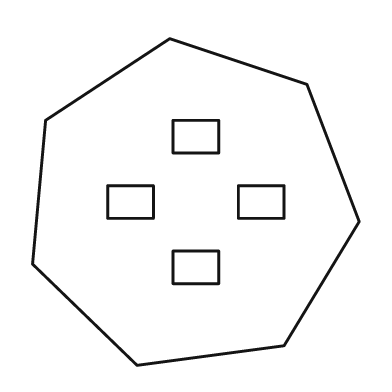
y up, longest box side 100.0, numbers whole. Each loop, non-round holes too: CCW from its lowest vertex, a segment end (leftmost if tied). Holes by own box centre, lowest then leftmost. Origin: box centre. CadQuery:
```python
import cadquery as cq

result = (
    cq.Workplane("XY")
    .moveTo(-18.0, -50.0)
    .lineTo(27.0, -44.0)
    .lineTo(50.0, -6.0)
    .lineTo(34.0, 36.0)
    .lineTo(-8.0, 50.0)
    .lineTo(-46.0, 25.0)
    .lineTo(-50.0, -19.0)
    .close()
    .moveTo(-7.0, -25.0)
    .lineTo(7.0, -25.0)
    .lineTo(7.0, -15.0)
    .lineTo(-7.0, -15.0)
    .close()
    .moveTo(-27.0, -5.0)
    .lineTo(-13.0, -5.0)
    .lineTo(-13.0, 5.0)
    .lineTo(-27.0, 5.0)
    .close()
    .moveTo(13.0, -5.0)
    .lineTo(27.0, -5.0)
    .lineTo(27.0, 5.0)
    .lineTo(13.0, 5.0)
    .close()
    .moveTo(-7.0, 15.0)
    .lineTo(7.0, 15.0)
    .lineTo(7.0, 25.0)
    .lineTo(-7.0, 25.0)
    .close()
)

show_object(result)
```